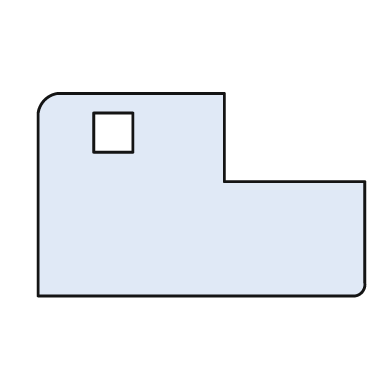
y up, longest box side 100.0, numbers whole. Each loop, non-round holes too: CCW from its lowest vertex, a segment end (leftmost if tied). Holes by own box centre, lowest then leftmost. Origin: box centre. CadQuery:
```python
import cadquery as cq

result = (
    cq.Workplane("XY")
    .moveTo(-50.0, -31.0)
    .lineTo(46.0, -31.0)
    .threePointArc((49.0, -30.0), (50.0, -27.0))
    .lineTo(50.0, 4.0)
    .lineTo(7.0, 4.0)
    .lineTo(7.0, 31.0)
    .lineTo(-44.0, 31.0)
    .threePointArc((-48.0, 29.0), (-50.0, 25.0))
    .close()
    .moveTo(-33.0, 13.0)
    .lineTo(-21.0, 13.0)
    .lineTo(-21.0, 25.0)
    .lineTo(-33.0, 25.0)
    .close()
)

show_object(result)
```